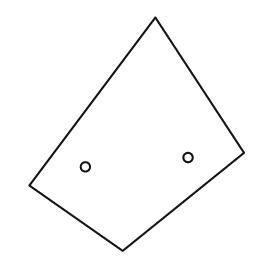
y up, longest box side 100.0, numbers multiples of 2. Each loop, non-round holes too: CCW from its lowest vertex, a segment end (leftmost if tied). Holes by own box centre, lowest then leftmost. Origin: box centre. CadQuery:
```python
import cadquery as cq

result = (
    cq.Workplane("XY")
    .moveTo(-6.0, -50.0)
    .lineTo(46.0, -8.0)
    .lineTo(8.0, 50.0)
    .lineTo(-46.0, -22.0)
    .close()
    .moveTo(-22.0, -14.0)
    .circle(2.0)
    .moveTo(22.0, -10.0)
    .circle(2.0)
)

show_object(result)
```